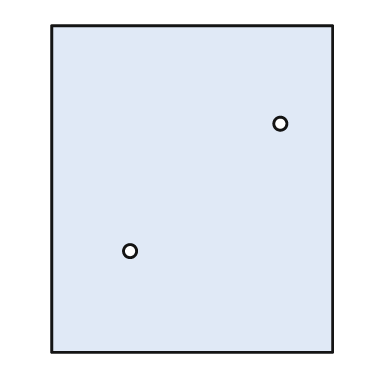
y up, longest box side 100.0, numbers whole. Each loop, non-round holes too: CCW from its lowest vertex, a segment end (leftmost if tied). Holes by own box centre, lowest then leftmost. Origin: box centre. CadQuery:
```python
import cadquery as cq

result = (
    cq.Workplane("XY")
    .moveTo(-43.0, -50.0)
    .lineTo(43.0, -50.0)
    .lineTo(43.0, 50.0)
    .lineTo(-43.0, 50.0)
    .close()
    .moveTo(-19.0, -19.0)
    .circle(2.0)
    .moveTo(27.0, 20.0)
    .circle(2.0)
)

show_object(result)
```